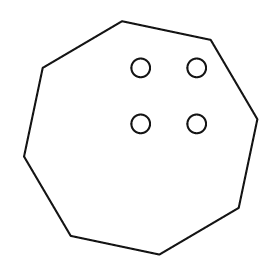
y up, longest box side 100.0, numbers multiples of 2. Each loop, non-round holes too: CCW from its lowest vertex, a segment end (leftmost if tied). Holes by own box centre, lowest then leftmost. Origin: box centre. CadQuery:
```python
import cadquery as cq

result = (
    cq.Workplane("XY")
    .moveTo(8.0, -50.0)
    .lineTo(42.0, -30.0)
    .lineTo(50.0, 8.0)
    .lineTo(30.0, 42.0)
    .lineTo(-8.0, 50.0)
    .lineTo(-42.0, 30.0)
    .lineTo(-50.0, -8.0)
    .lineTo(-30.0, -42.0)
    .close()
    .moveTo(0.0, 6.0)
    .circle(4.0)
    .moveTo(24.0, 6.0)
    .circle(4.0)
    .moveTo(0.0, 30.0)
    .circle(4.0)
    .moveTo(24.0, 30.0)
    .circle(4.0)
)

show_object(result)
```